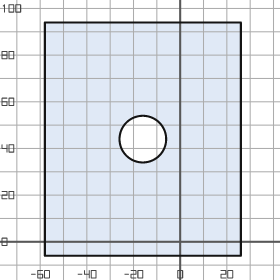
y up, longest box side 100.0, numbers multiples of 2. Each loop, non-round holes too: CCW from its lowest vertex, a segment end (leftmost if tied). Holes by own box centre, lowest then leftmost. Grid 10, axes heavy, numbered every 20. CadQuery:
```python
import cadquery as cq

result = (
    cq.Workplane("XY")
    .moveTo(-58.0, -6.0)
    .lineTo(26.0, -6.0)
    .lineTo(26.0, 94.0)
    .lineTo(-58.0, 94.0)
    .close()
    .moveTo(-16.0, 44.0)
    .circle(10.0)
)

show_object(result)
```